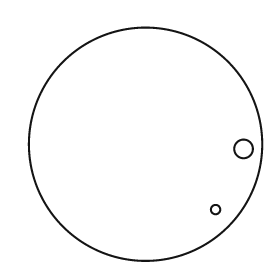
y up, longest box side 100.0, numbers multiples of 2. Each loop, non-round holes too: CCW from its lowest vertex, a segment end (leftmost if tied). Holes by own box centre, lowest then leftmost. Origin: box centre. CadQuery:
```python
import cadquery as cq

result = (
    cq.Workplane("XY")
    .moveTo(0.0, 0.0)
    .circle(50.0)
    .moveTo(30.0, -28.0)
    .circle(2.0)
    .moveTo(42.0, -2.0)
    .circle(4.0)
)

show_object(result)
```